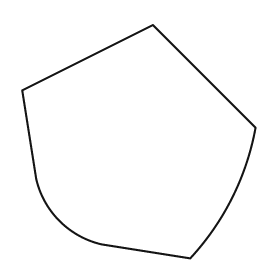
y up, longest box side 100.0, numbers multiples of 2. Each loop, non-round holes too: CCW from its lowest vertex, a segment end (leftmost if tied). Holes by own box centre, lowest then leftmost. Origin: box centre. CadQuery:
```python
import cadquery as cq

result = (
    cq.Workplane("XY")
    .moveTo(22.0, -50.0)
    .threePointArc((40.0, -24.0), (50.0, 6.0))
    .lineTo(6.0, 50.0)
    .lineTo(-50.0, 22.0)
    .lineTo(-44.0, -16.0)
    .threePointArc((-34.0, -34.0), (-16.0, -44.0))
    .close()
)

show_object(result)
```